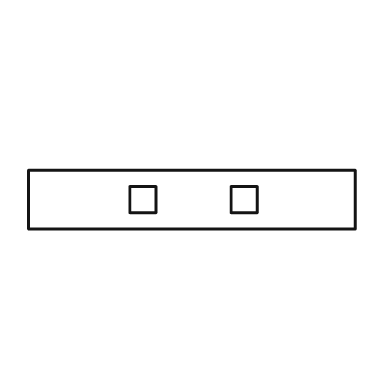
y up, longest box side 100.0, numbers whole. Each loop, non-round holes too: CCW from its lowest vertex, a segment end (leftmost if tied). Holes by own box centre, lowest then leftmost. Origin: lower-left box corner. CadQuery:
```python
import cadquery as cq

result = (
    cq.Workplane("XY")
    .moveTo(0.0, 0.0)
    .lineTo(100.0, 0.0)
    .lineTo(100.0, 18.0)
    .lineTo(0.0, 18.0)
    .close()
    .moveTo(31.0, 5.0)
    .lineTo(39.0, 5.0)
    .lineTo(39.0, 13.0)
    .lineTo(31.0, 13.0)
    .close()
    .moveTo(62.0, 5.0)
    .lineTo(70.0, 5.0)
    .lineTo(70.0, 13.0)
    .lineTo(62.0, 13.0)
    .close()
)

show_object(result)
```